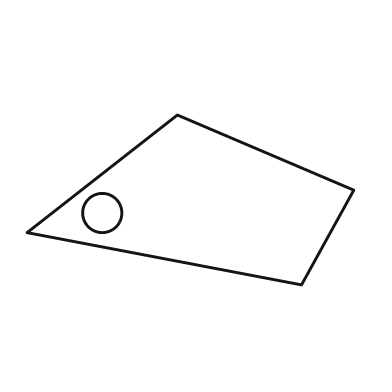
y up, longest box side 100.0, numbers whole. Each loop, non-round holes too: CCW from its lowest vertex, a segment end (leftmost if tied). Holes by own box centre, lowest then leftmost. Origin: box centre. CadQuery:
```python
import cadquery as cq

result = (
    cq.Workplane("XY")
    .moveTo(34.0, -26.0)
    .lineTo(50.0, 3.0)
    .lineTo(-4.0, 26.0)
    .lineTo(-50.0, -10.0)
    .close()
    .moveTo(-27.0, -4.0)
    .circle(6.0)
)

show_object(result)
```